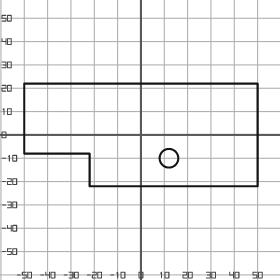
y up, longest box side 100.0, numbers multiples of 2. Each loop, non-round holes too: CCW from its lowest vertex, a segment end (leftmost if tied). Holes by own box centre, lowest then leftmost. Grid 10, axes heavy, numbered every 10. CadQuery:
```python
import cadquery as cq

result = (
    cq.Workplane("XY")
    .moveTo(-22.0, -22.0)
    .lineTo(50.0, -22.0)
    .lineTo(50.0, 22.0)
    .lineTo(-50.0, 22.0)
    .lineTo(-50.0, -8.0)
    .lineTo(-22.0, -8.0)
    .close()
    .moveTo(12.0, -10.0)
    .circle(4.0)
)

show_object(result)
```